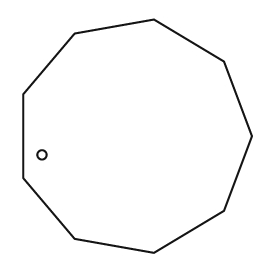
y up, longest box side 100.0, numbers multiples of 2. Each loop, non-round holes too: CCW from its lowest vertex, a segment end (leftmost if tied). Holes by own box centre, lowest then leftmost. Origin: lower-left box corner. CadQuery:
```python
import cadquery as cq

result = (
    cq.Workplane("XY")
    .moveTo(56.0, 0.0)
    .lineTo(86.0, 18.0)
    .lineTo(98.0, 50.0)
    .lineTo(86.0, 82.0)
    .lineTo(56.0, 100.0)
    .lineTo(22.0, 94.0)
    .lineTo(0.0, 68.0)
    .lineTo(0.0, 32.0)
    .lineTo(22.0, 6.0)
    .close()
    .moveTo(8.0, 42.0)
    .circle(2.0)
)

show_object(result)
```